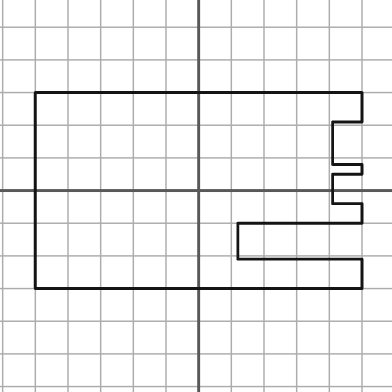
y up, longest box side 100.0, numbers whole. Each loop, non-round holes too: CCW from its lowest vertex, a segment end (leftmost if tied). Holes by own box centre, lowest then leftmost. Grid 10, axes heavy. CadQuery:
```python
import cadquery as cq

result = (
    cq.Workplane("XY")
    .moveTo(-50.0, -30.0)
    .lineTo(50.0, -30.0)
    .lineTo(50.0, -21.0)
    .lineTo(12.0, -21.0)
    .lineTo(12.0, -10.0)
    .lineTo(50.0, -10.0)
    .lineTo(50.0, -4.0)
    .lineTo(41.0, -4.0)
    .lineTo(41.0, 5.0)
    .lineTo(50.0, 5.0)
    .lineTo(50.0, 8.0)
    .lineTo(41.0, 8.0)
    .lineTo(41.0, 21.0)
    .lineTo(50.0, 21.0)
    .lineTo(50.0, 30.0)
    .lineTo(-50.0, 30.0)
    .close()
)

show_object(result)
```